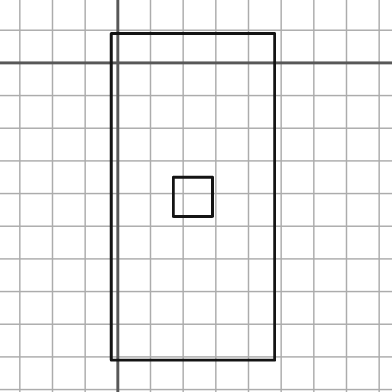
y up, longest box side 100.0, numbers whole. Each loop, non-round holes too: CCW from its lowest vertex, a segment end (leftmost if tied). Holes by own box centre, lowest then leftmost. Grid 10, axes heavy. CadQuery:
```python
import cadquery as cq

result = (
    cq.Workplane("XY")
    .moveTo(-2.0, -91.0)
    .lineTo(48.0, -91.0)
    .lineTo(48.0, 9.0)
    .lineTo(-2.0, 9.0)
    .close()
    .moveTo(17.0, -47.0)
    .lineTo(29.0, -47.0)
    .lineTo(29.0, -35.0)
    .lineTo(17.0, -35.0)
    .close()
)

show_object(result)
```